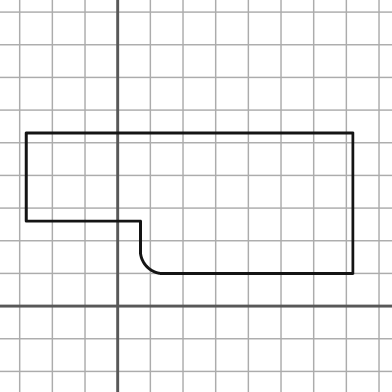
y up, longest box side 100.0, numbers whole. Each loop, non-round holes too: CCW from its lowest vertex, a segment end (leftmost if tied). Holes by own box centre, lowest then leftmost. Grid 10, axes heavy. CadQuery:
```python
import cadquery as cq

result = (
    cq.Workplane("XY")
    .moveTo(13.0, 10.0)
    .lineTo(72.0, 10.0)
    .lineTo(72.0, 53.0)
    .lineTo(-28.0, 53.0)
    .lineTo(-28.0, 26.0)
    .lineTo(7.0, 26.0)
    .lineTo(7.0, 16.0)
    .threePointArc((9.0, 12.0), (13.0, 10.0))
    .close()
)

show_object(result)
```